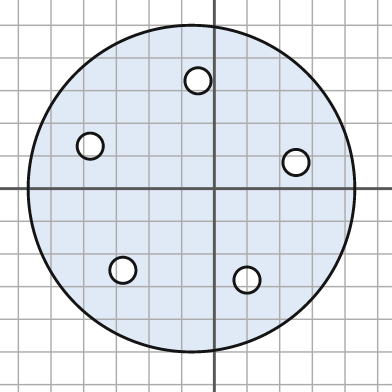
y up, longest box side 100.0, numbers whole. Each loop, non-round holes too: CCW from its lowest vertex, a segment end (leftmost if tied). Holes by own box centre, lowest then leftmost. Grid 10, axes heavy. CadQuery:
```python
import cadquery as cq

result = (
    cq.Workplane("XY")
    .moveTo(-7.0, 0.0)
    .circle(50.0)
    .moveTo(10.0, -28.0)
    .circle(4.0)
    .moveTo(-28.0, -25.0)
    .circle(4.0)
    .moveTo(25.0, 8.0)
    .circle(4.0)
    .moveTo(-38.0, 13.0)
    .circle(4.0)
    .moveTo(-5.0, 33.0)
    .circle(4.0)
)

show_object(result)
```